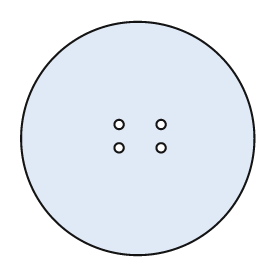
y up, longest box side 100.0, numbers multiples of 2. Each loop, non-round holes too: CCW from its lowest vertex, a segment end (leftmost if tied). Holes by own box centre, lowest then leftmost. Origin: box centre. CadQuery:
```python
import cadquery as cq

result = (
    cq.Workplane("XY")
    .moveTo(0.0, 0.0)
    .circle(50.0)
    .moveTo(-8.0, -4.0)
    .circle(2.0)
    .moveTo(10.0, -4.0)
    .circle(2.0)
    .moveTo(-8.0, 6.0)
    .circle(2.0)
    .moveTo(10.0, 6.0)
    .circle(2.0)
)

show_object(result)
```